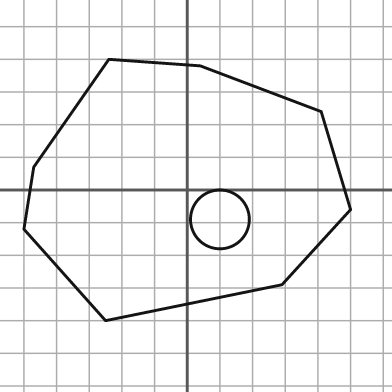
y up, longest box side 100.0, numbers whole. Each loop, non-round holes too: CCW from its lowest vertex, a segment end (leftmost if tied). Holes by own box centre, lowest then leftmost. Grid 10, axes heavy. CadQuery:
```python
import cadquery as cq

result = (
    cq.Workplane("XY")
    .moveTo(-25.0, -40.0)
    .lineTo(29.0, -29.0)
    .lineTo(50.0, -6.0)
    .lineTo(41.0, 24.0)
    .lineTo(4.0, 38.0)
    .lineTo(-24.0, 40.0)
    .lineTo(-47.0, 7.0)
    .lineTo(-50.0, -12.0)
    .close()
    .moveTo(10.0, -9.0)
    .circle(9.0)
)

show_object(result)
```